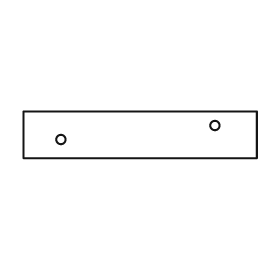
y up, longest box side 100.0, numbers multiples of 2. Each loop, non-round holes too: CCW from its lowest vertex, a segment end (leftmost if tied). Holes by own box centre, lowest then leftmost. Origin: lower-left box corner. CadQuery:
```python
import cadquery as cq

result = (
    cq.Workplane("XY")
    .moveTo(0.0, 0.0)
    .lineTo(100.0, 0.0)
    .lineTo(100.0, 20.0)
    .lineTo(0.0, 20.0)
    .close()
    .moveTo(16.0, 8.0)
    .circle(2.0)
    .moveTo(82.0, 14.0)
    .circle(2.0)
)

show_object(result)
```